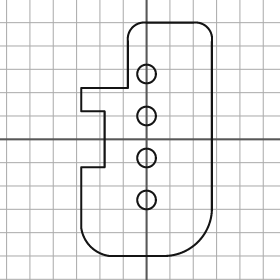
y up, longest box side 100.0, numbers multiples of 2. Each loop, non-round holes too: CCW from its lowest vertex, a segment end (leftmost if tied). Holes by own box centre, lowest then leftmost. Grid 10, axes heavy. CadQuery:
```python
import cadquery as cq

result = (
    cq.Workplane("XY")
    .moveTo(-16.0, -50.0)
    .lineTo(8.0, -50.0)
    .threePointArc((22.0, -44.0), (28.0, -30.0))
    .lineTo(28.0, 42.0)
    .threePointArc((26.0, 48.0), (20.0, 50.0))
    .lineTo(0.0, 50.0)
    .threePointArc((-6.0, 48.0), (-8.0, 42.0))
    .lineTo(-8.0, 22.0)
    .lineTo(-28.0, 22.0)
    .lineTo(-28.0, 12.0)
    .lineTo(-18.0, 12.0)
    .lineTo(-18.0, -12.0)
    .lineTo(-28.0, -12.0)
    .lineTo(-28.0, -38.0)
    .threePointArc((-24.0, -46.0), (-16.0, -50.0))
    .close()
    .moveTo(0.0, -26.0)
    .circle(4.0)
    .moveTo(0.0, -8.0)
    .circle(4.0)
    .moveTo(0.0, 10.0)
    .circle(4.0)
    .moveTo(0.0, 28.0)
    .circle(4.0)
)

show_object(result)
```